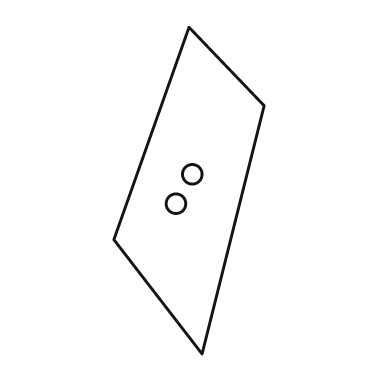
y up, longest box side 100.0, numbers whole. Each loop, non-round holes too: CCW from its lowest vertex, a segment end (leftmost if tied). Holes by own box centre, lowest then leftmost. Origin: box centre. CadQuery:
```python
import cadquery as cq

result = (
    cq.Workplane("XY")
    .moveTo(4.0, -50.0)
    .lineTo(23.0, 26.0)
    .lineTo(0.0, 50.0)
    .lineTo(-23.0, -15.0)
    .close()
    .moveTo(-4.0, -4.0)
    .circle(3.0)
    .moveTo(1.0, 5.0)
    .circle(3.0)
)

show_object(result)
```